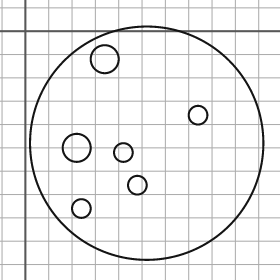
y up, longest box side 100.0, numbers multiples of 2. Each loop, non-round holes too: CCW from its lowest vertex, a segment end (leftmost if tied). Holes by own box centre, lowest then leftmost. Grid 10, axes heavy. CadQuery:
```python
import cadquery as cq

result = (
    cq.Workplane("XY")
    .moveTo(52.0, -48.0)
    .circle(50.0)
    .moveTo(24.0, -76.0)
    .circle(4.0)
    .moveTo(48.0, -66.0)
    .circle(4.0)
    .moveTo(42.0, -52.0)
    .circle(4.0)
    .moveTo(22.0, -50.0)
    .circle(6.0)
    .moveTo(74.0, -36.0)
    .circle(4.0)
    .moveTo(34.0, -12.0)
    .circle(6.0)
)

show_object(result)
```